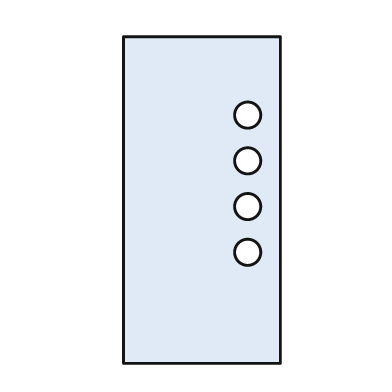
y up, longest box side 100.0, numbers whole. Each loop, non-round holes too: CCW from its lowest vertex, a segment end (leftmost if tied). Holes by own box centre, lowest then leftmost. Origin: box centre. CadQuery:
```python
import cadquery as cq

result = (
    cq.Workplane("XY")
    .moveTo(-24.0, -50.0)
    .lineTo(24.0, -50.0)
    .lineTo(24.0, 50.0)
    .lineTo(-24.0, 50.0)
    .close()
    .moveTo(14.0, -16.0)
    .circle(4.0)
    .moveTo(14.0, -2.0)
    .circle(4.0)
    .moveTo(14.0, 12.0)
    .circle(4.0)
    .moveTo(14.0, 26.0)
    .circle(4.0)
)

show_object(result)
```